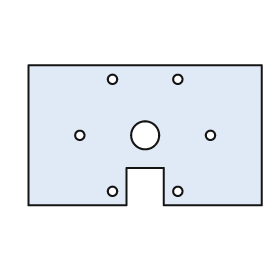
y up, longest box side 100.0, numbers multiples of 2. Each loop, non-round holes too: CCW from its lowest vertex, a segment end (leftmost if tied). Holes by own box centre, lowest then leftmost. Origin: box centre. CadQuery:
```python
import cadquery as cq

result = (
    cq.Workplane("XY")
    .moveTo(-50.0, -30.0)
    .lineTo(-8.0, -30.0)
    .lineTo(-8.0, -14.0)
    .lineTo(8.0, -14.0)
    .lineTo(8.0, -30.0)
    .lineTo(50.0, -30.0)
    .lineTo(50.0, 30.0)
    .lineTo(-50.0, 30.0)
    .close()
    .moveTo(-14.0, -24.0)
    .circle(2.0)
    .moveTo(14.0, -24.0)
    .circle(2.0)
    .moveTo(-28.0, 0.0)
    .circle(2.0)
    .moveTo(0.0, 0.0)
    .circle(6.0)
    .moveTo(28.0, 0.0)
    .circle(2.0)
    .moveTo(-14.0, 24.0)
    .circle(2.0)
    .moveTo(14.0, 24.0)
    .circle(2.0)
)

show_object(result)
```